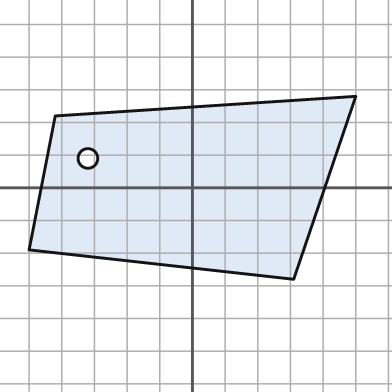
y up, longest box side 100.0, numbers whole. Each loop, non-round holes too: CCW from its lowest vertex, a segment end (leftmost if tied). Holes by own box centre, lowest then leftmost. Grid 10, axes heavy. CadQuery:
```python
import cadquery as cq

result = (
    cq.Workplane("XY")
    .moveTo(31.0, -28.0)
    .lineTo(50.0, 28.0)
    .lineTo(-42.0, 22.0)
    .lineTo(-50.0, -19.0)
    .close()
    .moveTo(-32.0, 9.0)
    .circle(3.0)
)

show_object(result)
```